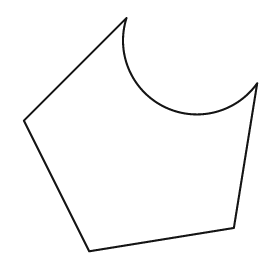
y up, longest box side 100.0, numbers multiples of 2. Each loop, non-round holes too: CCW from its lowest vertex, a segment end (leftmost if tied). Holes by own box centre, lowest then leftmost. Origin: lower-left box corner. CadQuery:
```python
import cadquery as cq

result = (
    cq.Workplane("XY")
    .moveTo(28.0, 0.0)
    .lineTo(90.0, 10.0)
    .lineTo(100.0, 72.0)
    .threePointArc((60.0, 62.0), (44.0, 100.0))
    .lineTo(0.0, 56.0)
    .close()
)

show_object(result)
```